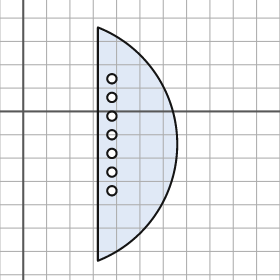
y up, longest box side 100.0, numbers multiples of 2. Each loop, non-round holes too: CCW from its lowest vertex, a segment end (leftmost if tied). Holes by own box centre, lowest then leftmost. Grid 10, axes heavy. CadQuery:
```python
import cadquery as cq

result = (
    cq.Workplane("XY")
    .moveTo(32.0, -64.0)
    .threePointArc((66.0, -14.0), (32.0, 36.0))
    .close()
    .moveTo(38.0, -34.0)
    .circle(2.0)
    .moveTo(38.0, -26.0)
    .circle(2.0)
    .moveTo(38.0, -18.0)
    .circle(2.0)
    .moveTo(38.0, -10.0)
    .circle(2.0)
    .moveTo(38.0, -2.0)
    .circle(2.0)
    .moveTo(38.0, 6.0)
    .circle(2.0)
    .moveTo(38.0, 14.0)
    .circle(2.0)
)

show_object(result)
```